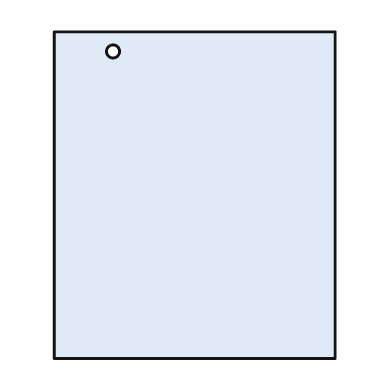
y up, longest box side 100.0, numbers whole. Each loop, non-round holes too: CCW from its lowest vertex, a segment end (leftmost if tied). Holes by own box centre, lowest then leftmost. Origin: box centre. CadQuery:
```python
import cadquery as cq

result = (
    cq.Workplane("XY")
    .moveTo(-43.0, -50.0)
    .lineTo(43.0, -50.0)
    .lineTo(43.0, 50.0)
    .lineTo(-43.0, 50.0)
    .close()
    .moveTo(-25.0, 44.0)
    .circle(2.0)
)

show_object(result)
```